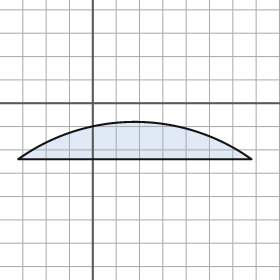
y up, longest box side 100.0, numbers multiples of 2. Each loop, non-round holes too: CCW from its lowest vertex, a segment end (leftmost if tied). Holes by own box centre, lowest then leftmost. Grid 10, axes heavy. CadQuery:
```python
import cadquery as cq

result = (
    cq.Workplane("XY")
    .moveTo(-32.0, -24.0)
    .lineTo(68.0, -24.0)
    .threePointArc((18.0, -8.0), (-32.0, -24.0))
    .close()
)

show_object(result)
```